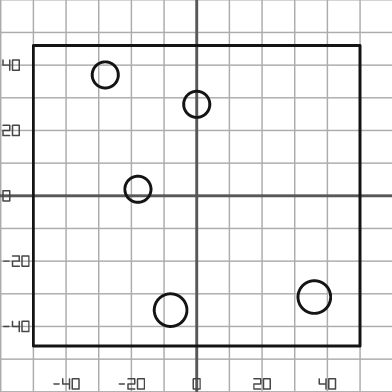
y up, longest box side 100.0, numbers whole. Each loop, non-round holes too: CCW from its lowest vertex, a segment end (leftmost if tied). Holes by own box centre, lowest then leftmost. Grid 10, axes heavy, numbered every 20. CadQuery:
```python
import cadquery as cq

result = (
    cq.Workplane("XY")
    .moveTo(-50.0, -46.0)
    .lineTo(50.0, -46.0)
    .lineTo(50.0, 46.0)
    .lineTo(-50.0, 46.0)
    .close()
    .moveTo(-8.0, -35.0)
    .circle(5.0)
    .moveTo(36.0, -31.0)
    .circle(5.0)
    .moveTo(-18.0, 2.0)
    .circle(4.0)
    .moveTo(0.0, 28.0)
    .circle(4.0)
    .moveTo(-28.0, 37.0)
    .circle(4.0)
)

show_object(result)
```